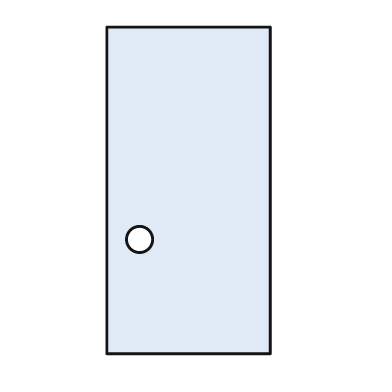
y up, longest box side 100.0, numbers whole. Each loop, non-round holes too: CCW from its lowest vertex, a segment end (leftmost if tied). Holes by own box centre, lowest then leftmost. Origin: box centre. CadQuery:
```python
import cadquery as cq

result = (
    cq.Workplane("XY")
    .moveTo(-25.0, -50.0)
    .lineTo(25.0, -50.0)
    .lineTo(25.0, 50.0)
    .lineTo(-25.0, 50.0)
    .close()
    .moveTo(-15.0, -15.0)
    .circle(4.0)
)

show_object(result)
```